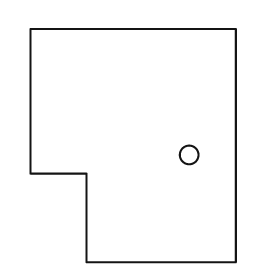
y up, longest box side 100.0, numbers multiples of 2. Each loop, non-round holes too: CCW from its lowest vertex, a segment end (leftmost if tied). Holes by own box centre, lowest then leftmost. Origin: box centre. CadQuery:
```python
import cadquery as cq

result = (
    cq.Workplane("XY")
    .moveTo(-20.0, -50.0)
    .lineTo(44.0, -50.0)
    .lineTo(44.0, 50.0)
    .lineTo(-44.0, 50.0)
    .lineTo(-44.0, -12.0)
    .lineTo(-20.0, -12.0)
    .close()
    .moveTo(24.0, -4.0)
    .circle(4.0)
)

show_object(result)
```